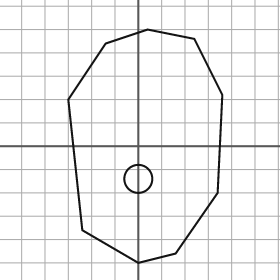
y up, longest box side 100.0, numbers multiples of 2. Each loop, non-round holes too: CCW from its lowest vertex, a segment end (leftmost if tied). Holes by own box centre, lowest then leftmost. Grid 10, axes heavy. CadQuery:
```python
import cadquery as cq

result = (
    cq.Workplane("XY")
    .moveTo(0.0, -50.0)
    .lineTo(16.0, -46.0)
    .lineTo(34.0, -20.0)
    .lineTo(36.0, 22.0)
    .lineTo(24.0, 46.0)
    .lineTo(4.0, 50.0)
    .lineTo(-14.0, 44.0)
    .lineTo(-30.0, 20.0)
    .lineTo(-24.0, -36.0)
    .close()
    .moveTo(0.0, -14.0)
    .circle(6.0)
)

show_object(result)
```